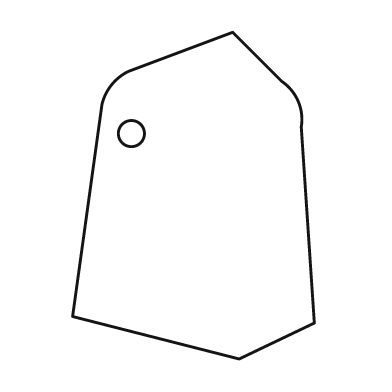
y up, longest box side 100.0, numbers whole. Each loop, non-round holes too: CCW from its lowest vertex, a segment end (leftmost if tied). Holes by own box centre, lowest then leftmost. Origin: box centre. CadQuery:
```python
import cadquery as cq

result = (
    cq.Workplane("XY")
    .moveTo(14.0, -50.0)
    .lineTo(37.0, -39.0)
    .lineTo(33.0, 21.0)
    .threePointArc((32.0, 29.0), (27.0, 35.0))
    .lineTo(12.0, 50.0)
    .lineTo(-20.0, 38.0)
    .threePointArc((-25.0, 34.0), (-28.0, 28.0))
    .lineTo(-37.0, -37.0)
    .close()
    .moveTo(-19.0, 19.0)
    .circle(4.0)
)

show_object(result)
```